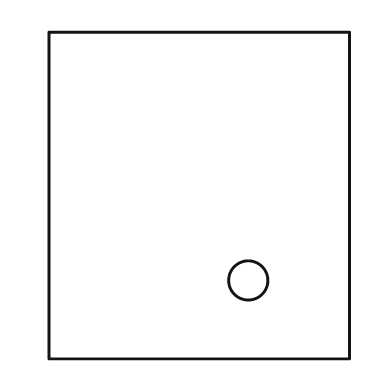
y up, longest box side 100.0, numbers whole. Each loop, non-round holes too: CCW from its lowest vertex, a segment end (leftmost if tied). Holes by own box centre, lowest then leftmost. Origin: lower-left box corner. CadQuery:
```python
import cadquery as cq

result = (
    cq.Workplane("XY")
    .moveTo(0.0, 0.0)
    .lineTo(92.0, 0.0)
    .lineTo(92.0, 100.0)
    .lineTo(0.0, 100.0)
    .close()
    .moveTo(61.0, 24.0)
    .circle(6.0)
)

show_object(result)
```